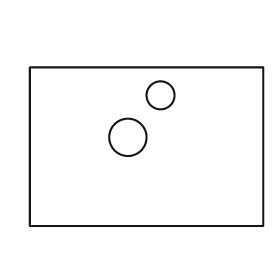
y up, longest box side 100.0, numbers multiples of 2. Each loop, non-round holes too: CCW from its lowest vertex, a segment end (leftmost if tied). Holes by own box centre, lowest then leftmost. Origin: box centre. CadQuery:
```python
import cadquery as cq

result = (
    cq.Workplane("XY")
    .moveTo(-50.0, -34.0)
    .lineTo(50.0, -34.0)
    .lineTo(50.0, 34.0)
    .lineTo(-50.0, 34.0)
    .close()
    .moveTo(-8.0, 4.0)
    .circle(8.0)
    .moveTo(6.0, 22.0)
    .circle(6.0)
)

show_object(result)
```